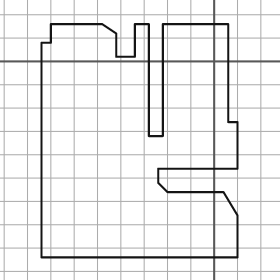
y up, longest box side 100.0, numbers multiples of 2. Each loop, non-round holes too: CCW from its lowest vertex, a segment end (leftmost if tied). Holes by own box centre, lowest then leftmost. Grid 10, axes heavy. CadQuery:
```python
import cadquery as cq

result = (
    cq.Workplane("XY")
    .moveTo(-74.0, -84.0)
    .lineTo(10.0, -84.0)
    .lineTo(10.0, -66.0)
    .lineTo(4.0, -56.0)
    .lineTo(-20.0, -56.0)
    .lineTo(-24.0, -52.0)
    .lineTo(-24.0, -46.0)
    .lineTo(10.0, -46.0)
    .lineTo(10.0, -26.0)
    .lineTo(6.0, -26.0)
    .lineTo(6.0, 16.0)
    .lineTo(-22.0, 16.0)
    .lineTo(-22.0, -32.0)
    .lineTo(-28.0, -32.0)
    .lineTo(-28.0, 16.0)
    .lineTo(-34.0, 16.0)
    .lineTo(-34.0, 2.0)
    .lineTo(-42.0, 2.0)
    .lineTo(-42.0, 12.0)
    .lineTo(-48.0, 16.0)
    .lineTo(-70.0, 16.0)
    .lineTo(-70.0, 8.0)
    .lineTo(-74.0, 8.0)
    .close()
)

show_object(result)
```